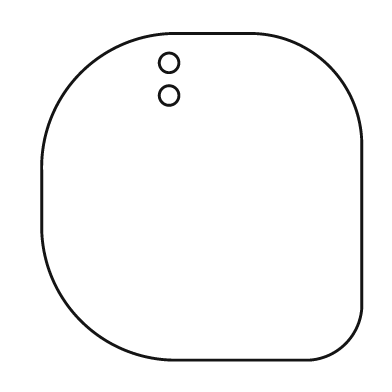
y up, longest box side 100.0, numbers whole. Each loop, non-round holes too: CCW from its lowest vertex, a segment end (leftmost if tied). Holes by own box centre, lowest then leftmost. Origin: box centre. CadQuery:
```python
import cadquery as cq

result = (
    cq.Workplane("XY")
    .moveTo(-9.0, -50.0)
    .lineTo(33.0, -50.0)
    .threePointArc((44.0, -45.0), (49.0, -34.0))
    .lineTo(49.0, 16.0)
    .threePointArc((39.0, 40.0), (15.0, 50.0))
    .lineTo(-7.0, 50.0)
    .threePointArc((-37.0, 38.0), (-49.0, 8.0))
    .lineTo(-49.0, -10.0)
    .threePointArc((-37.0, -38.0), (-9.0, -50.0))
    .close()
    .moveTo(-10.0, 31.0)
    .circle(3.0)
    .moveTo(-10.0, 41.0)
    .circle(3.0)
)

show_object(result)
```